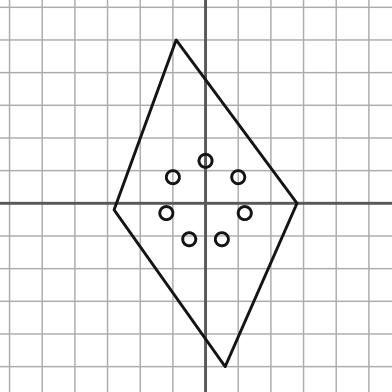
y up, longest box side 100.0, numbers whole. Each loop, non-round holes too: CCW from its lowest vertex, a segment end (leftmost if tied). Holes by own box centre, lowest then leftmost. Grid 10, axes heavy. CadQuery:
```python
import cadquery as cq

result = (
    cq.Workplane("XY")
    .moveTo(6.0, -50.0)
    .lineTo(28.0, 0.0)
    .lineTo(-9.0, 50.0)
    .lineTo(-28.0, -2.0)
    .close()
    .moveTo(-5.0, -11.0)
    .circle(2.0)
    .moveTo(5.0, -11.0)
    .circle(2.0)
    .moveTo(-12.0, -3.0)
    .circle(2.0)
    .moveTo(12.0, -3.0)
    .circle(2.0)
    .moveTo(-10.0, 8.0)
    .circle(2.0)
    .moveTo(10.0, 8.0)
    .circle(2.0)
    .moveTo(0.0, 13.0)
    .circle(2.0)
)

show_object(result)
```